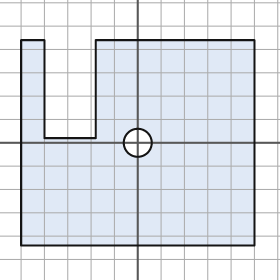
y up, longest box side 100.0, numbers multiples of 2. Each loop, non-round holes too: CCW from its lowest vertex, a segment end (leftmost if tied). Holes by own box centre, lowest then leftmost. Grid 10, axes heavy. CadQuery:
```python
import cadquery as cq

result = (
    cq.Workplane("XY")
    .moveTo(-50.0, -44.0)
    .lineTo(50.0, -44.0)
    .lineTo(50.0, 44.0)
    .lineTo(-18.0, 44.0)
    .lineTo(-18.0, 2.0)
    .lineTo(-40.0, 2.0)
    .lineTo(-40.0, 44.0)
    .lineTo(-50.0, 44.0)
    .close()
    .moveTo(0.0, 0.0)
    .circle(6.0)
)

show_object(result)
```